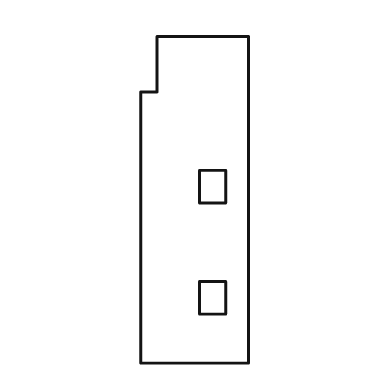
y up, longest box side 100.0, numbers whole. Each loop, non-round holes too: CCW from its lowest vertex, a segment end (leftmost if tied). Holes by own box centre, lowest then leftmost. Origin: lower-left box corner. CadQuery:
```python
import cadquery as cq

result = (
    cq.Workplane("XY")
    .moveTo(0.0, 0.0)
    .lineTo(33.0, 0.0)
    .lineTo(33.0, 100.0)
    .lineTo(5.0, 100.0)
    .lineTo(5.0, 83.0)
    .lineTo(0.0, 83.0)
    .close()
    .moveTo(18.0, 15.0)
    .lineTo(26.0, 15.0)
    .lineTo(26.0, 25.0)
    .lineTo(18.0, 25.0)
    .close()
    .moveTo(18.0, 49.0)
    .lineTo(26.0, 49.0)
    .lineTo(26.0, 59.0)
    .lineTo(18.0, 59.0)
    .close()
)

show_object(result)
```